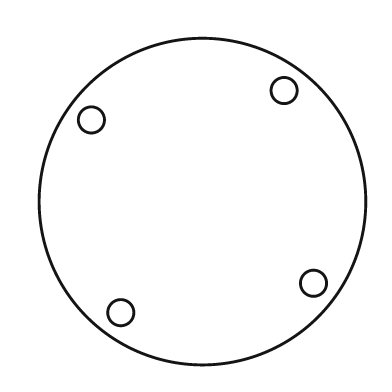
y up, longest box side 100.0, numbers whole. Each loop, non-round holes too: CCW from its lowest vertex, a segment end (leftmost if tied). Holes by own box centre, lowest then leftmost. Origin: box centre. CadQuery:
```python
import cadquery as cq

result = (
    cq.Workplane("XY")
    .moveTo(0.0, 0.0)
    .circle(50.0)
    .moveTo(-25.0, -34.0)
    .circle(4.0)
    .moveTo(34.0, -25.0)
    .circle(4.0)
    .moveTo(-34.0, 25.0)
    .circle(4.0)
    .moveTo(25.0, 34.0)
    .circle(4.0)
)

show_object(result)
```